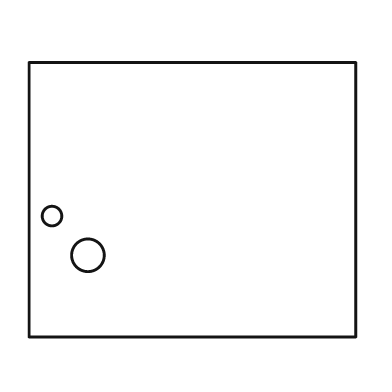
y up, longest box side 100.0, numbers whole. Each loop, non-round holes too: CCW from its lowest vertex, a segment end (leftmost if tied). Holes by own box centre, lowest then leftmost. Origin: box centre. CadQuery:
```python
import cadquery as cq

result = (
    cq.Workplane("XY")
    .moveTo(-50.0, -42.0)
    .lineTo(50.0, -42.0)
    .lineTo(50.0, 42.0)
    .lineTo(-50.0, 42.0)
    .close()
    .moveTo(-32.0, -17.0)
    .circle(5.0)
    .moveTo(-43.0, -5.0)
    .circle(3.0)
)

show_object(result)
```